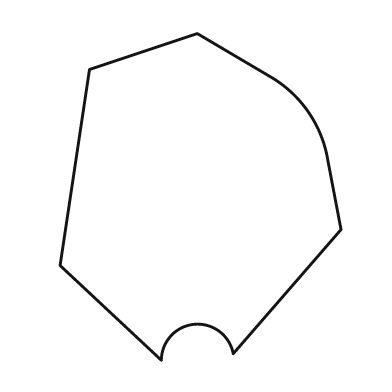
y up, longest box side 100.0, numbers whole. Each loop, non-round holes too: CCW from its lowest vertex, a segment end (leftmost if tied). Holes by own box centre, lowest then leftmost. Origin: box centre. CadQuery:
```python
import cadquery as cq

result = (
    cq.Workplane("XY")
    .moveTo(-12.0, -50.0)
    .threePointArc((-2.0, -39.0), (10.0, -48.0))
    .lineTo(43.0, -10.0)
    .lineTo(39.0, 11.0)
    .threePointArc((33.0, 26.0), (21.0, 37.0))
    .lineTo(-1.0, 50.0)
    .lineTo(-34.0, 39.0)
    .lineTo(-43.0, -21.0)
    .close()
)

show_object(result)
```